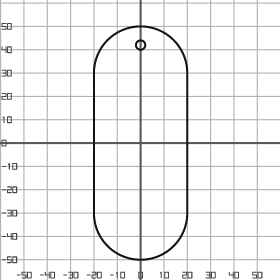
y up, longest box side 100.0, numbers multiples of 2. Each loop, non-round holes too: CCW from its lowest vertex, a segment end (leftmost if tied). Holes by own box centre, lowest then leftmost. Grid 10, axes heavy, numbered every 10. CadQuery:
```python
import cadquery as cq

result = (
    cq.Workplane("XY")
    .moveTo(-20.0, -30.0)
    .threePointArc((0.0, -50.0), (20.0, -30.0))
    .lineTo(20.0, 30.0)
    .threePointArc((0.0, 50.0), (-20.0, 30.0))
    .close()
    .moveTo(0.0, 42.0)
    .circle(2.0)
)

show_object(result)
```